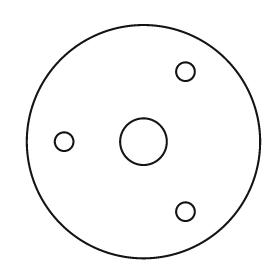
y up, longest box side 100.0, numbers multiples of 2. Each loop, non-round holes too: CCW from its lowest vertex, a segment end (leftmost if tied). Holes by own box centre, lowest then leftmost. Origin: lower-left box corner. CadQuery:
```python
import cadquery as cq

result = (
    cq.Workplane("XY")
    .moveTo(50.0, 50.0)
    .circle(50.0)
    .moveTo(68.0, 20.0)
    .circle(4.0)
    .moveTo(16.0, 50.0)
    .circle(4.0)
    .moveTo(50.0, 50.0)
    .circle(10.0)
    .moveTo(68.0, 80.0)
    .circle(4.0)
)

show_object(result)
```